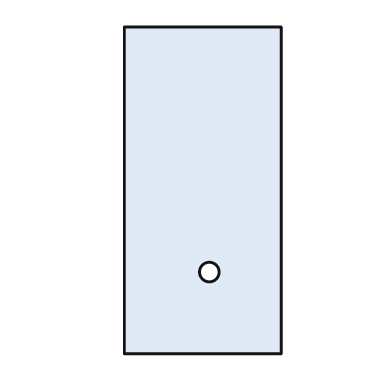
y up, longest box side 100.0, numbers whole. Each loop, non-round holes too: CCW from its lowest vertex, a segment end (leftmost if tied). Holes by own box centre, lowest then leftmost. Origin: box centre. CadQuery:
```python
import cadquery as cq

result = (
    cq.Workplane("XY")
    .moveTo(-24.0, -50.0)
    .lineTo(24.0, -50.0)
    .lineTo(24.0, 50.0)
    .lineTo(-24.0, 50.0)
    .close()
    .moveTo(2.0, -25.0)
    .circle(3.0)
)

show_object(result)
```